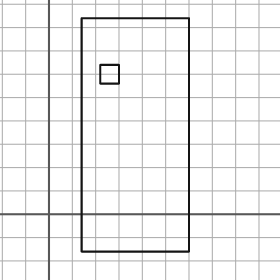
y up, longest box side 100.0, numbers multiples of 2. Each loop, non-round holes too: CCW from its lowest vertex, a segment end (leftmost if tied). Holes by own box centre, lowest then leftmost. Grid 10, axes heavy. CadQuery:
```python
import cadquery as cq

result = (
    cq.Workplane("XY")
    .moveTo(14.0, -16.0)
    .lineTo(60.0, -16.0)
    .lineTo(60.0, 84.0)
    .lineTo(14.0, 84.0)
    .close()
    .moveTo(22.0, 56.0)
    .lineTo(30.0, 56.0)
    .lineTo(30.0, 64.0)
    .lineTo(22.0, 64.0)
    .close()
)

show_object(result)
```